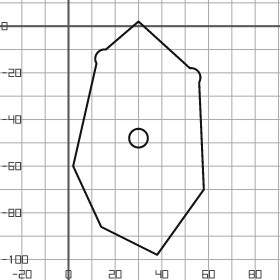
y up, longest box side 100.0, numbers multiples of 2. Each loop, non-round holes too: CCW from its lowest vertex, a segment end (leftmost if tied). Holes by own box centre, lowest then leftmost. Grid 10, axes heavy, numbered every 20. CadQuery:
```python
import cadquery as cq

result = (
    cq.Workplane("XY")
    .moveTo(38.0, -98.0)
    .lineTo(58.0, -70.0)
    .lineTo(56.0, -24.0)
    .threePointArc((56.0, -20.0), (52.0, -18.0))
    .lineTo(30.0, 2.0)
    .lineTo(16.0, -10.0)
    .threePointArc((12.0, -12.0), (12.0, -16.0))
    .lineTo(2.0, -60.0)
    .lineTo(14.0, -86.0)
    .close()
    .moveTo(30.0, -48.0)
    .circle(4.0)
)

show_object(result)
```